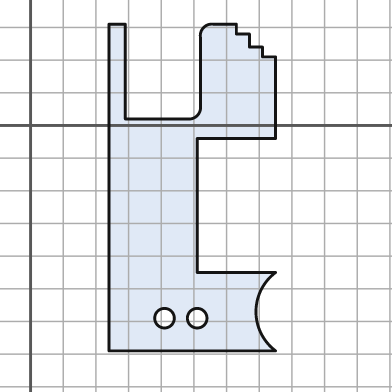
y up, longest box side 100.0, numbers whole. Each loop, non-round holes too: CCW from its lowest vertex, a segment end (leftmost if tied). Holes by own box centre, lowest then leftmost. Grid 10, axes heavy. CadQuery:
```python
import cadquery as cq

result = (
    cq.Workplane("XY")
    .moveTo(24.0, -69.0)
    .lineTo(75.0, -69.0)
    .threePointArc((69.0, -57.0), (75.0, -45.0))
    .lineTo(51.0, -45.0)
    .lineTo(51.0, -4.0)
    .lineTo(75.0, -4.0)
    .lineTo(75.0, 21.0)
    .lineTo(71.0, 21.0)
    .lineTo(71.0, 24.0)
    .lineTo(67.0, 24.0)
    .lineTo(67.0, 28.0)
    .lineTo(63.0, 28.0)
    .lineTo(63.0, 31.0)
    .lineTo(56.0, 31.0)
    .threePointArc((53.0, 30.0), (52.0, 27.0))
    .lineTo(52.0, 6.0)
    .threePointArc((51.0, 3.0), (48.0, 2.0))
    .lineTo(29.0, 2.0)
    .lineTo(29.0, 31.0)
    .lineTo(24.0, 31.0)
    .close()
    .moveTo(41.0, -59.0)
    .circle(3.0)
    .moveTo(51.0, -59.0)
    .circle(3.0)
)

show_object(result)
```